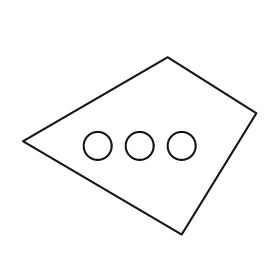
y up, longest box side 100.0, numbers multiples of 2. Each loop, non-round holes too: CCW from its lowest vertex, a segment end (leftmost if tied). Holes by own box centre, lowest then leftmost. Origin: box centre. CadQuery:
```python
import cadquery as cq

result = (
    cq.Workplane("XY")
    .moveTo(18.0, -38.0)
    .lineTo(50.0, 14.0)
    .lineTo(12.0, 38.0)
    .lineTo(-50.0, 2.0)
    .close()
    .moveTo(-18.0, 0.0)
    .circle(6.0)
    .moveTo(0.0, 0.0)
    .circle(6.0)
    .moveTo(18.0, 0.0)
    .circle(6.0)
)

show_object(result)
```